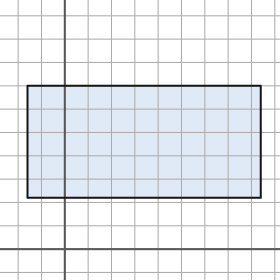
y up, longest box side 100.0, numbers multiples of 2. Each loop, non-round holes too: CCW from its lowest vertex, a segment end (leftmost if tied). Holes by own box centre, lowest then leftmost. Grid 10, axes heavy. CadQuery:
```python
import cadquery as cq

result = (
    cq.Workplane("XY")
    .moveTo(-16.0, 22.0)
    .lineTo(84.0, 22.0)
    .lineTo(84.0, 70.0)
    .lineTo(-16.0, 70.0)
    .close()
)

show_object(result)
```